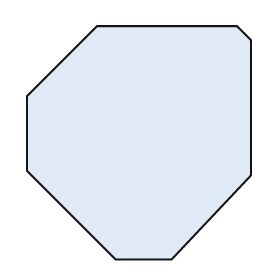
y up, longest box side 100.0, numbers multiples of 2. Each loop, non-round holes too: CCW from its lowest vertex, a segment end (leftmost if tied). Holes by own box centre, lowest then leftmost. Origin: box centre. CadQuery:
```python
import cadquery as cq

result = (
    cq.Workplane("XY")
    .moveTo(-10.0, -50.0)
    .lineTo(14.0, -50.0)
    .lineTo(48.0, -14.0)
    .lineTo(48.0, 44.0)
    .lineTo(42.0, 50.0)
    .lineTo(-18.0, 50.0)
    .lineTo(-48.0, 20.0)
    .lineTo(-48.0, -12.0)
    .close()
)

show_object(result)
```